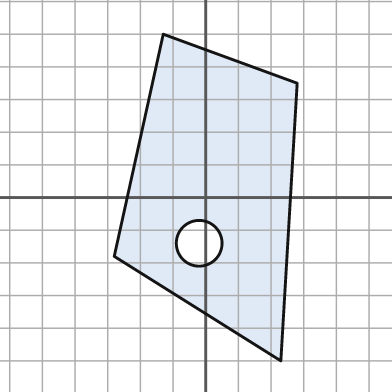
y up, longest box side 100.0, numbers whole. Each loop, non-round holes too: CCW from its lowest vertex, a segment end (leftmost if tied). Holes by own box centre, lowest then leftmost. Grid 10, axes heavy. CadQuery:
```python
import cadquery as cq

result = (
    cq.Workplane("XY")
    .moveTo(23.0, -50.0)
    .lineTo(28.0, 35.0)
    .lineTo(-13.0, 50.0)
    .lineTo(-28.0, -18.0)
    .close()
    .moveTo(-2.0, -14.0)
    .circle(7.0)
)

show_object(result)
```